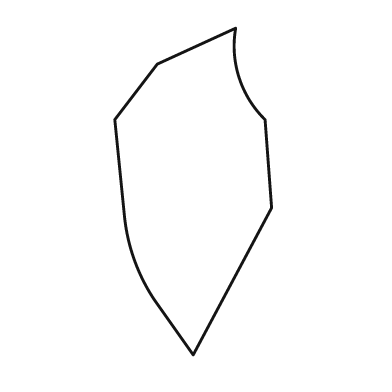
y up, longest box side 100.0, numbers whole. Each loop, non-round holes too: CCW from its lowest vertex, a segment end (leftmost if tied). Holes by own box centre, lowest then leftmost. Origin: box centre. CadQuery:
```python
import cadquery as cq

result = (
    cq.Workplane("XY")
    .moveTo(0.0, -50.0)
    .lineTo(24.0, -5.0)
    .lineTo(22.0, 22.0)
    .threePointArc((14.0, 35.0), (13.0, 50.0))
    .lineTo(-11.0, 39.0)
    .lineTo(-24.0, 22.0)
    .lineTo(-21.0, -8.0)
    .threePointArc((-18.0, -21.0), (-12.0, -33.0))
    .close()
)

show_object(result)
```